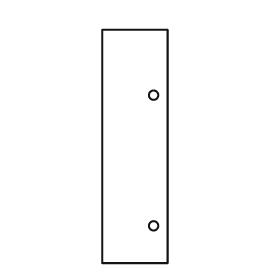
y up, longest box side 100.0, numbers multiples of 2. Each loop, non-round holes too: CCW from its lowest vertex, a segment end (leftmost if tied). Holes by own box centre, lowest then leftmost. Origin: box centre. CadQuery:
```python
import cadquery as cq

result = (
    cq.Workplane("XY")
    .moveTo(-14.0, -50.0)
    .lineTo(14.0, -50.0)
    .lineTo(14.0, 50.0)
    .lineTo(-14.0, 50.0)
    .close()
    .moveTo(8.0, -34.0)
    .circle(2.0)
    .moveTo(8.0, 22.0)
    .circle(2.0)
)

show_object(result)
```